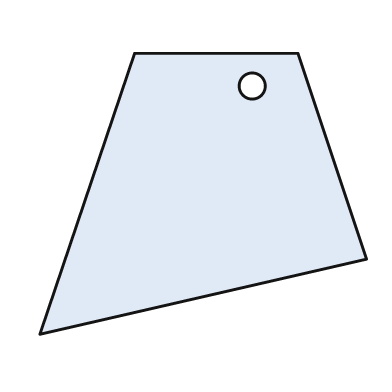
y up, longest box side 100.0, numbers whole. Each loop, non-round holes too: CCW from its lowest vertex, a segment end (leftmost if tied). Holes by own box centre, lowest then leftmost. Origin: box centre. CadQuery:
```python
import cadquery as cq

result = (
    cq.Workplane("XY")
    .moveTo(-50.0, -43.0)
    .lineTo(50.0, -20.0)
    .lineTo(29.0, 43.0)
    .lineTo(-21.0, 43.0)
    .close()
    .moveTo(15.0, 33.0)
    .circle(4.0)
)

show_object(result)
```